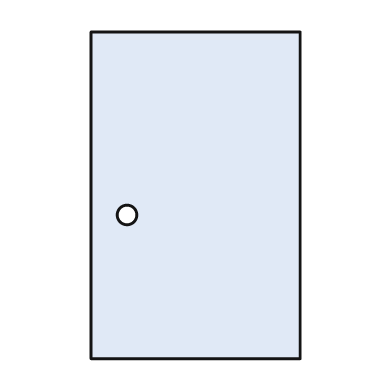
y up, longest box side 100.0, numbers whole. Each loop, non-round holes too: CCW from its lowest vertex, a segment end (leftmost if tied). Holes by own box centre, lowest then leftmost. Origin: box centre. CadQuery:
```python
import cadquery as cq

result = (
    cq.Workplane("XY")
    .moveTo(-32.0, -50.0)
    .lineTo(32.0, -50.0)
    .lineTo(32.0, 50.0)
    .lineTo(-32.0, 50.0)
    .close()
    .moveTo(-21.0, -6.0)
    .circle(3.0)
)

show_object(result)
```